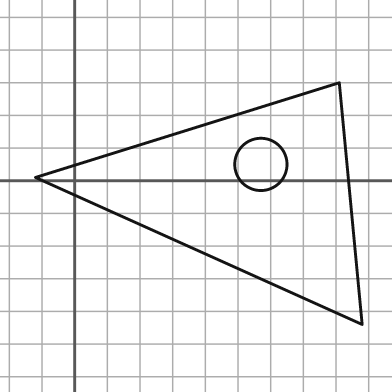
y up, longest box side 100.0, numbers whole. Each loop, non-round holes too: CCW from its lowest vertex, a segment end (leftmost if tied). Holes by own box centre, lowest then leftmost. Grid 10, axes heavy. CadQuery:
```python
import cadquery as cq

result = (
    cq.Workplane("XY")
    .moveTo(88.0, -44.0)
    .lineTo(81.0, 30.0)
    .lineTo(-12.0, 1.0)
    .close()
    .moveTo(57.0, 5.0)
    .circle(8.0)
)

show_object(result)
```